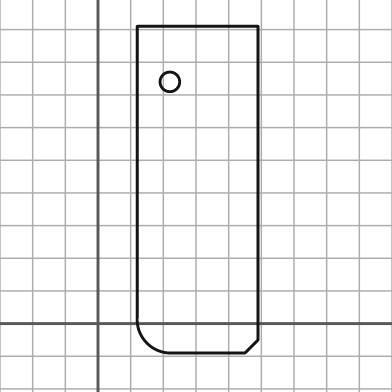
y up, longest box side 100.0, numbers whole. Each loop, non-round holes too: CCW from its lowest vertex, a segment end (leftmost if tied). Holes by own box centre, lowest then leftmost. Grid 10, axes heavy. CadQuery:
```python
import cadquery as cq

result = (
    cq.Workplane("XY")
    .moveTo(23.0, -9.0)
    .lineTo(45.0, -9.0)
    .lineTo(49.0, -5.0)
    .lineTo(49.0, 91.0)
    .lineTo(12.0, 91.0)
    .lineTo(12.0, 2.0)
    .threePointArc((15.0, -6.0), (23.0, -9.0))
    .close()
    .moveTo(22.0, 74.0)
    .circle(3.0)
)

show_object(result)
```